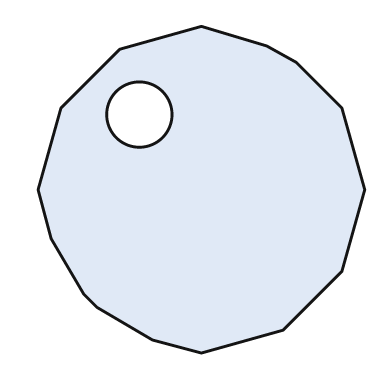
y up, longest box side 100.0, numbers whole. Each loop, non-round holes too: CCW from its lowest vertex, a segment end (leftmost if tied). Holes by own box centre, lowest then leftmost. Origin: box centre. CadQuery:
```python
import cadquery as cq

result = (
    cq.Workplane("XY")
    .moveTo(0.0, -50.0)
    .lineTo(25.0, -43.0)
    .lineTo(43.0, -25.0)
    .lineTo(50.0, 0.0)
    .lineTo(43.0, 25.0)
    .lineTo(29.0, 39.0)
    .lineTo(20.0, 44.0)
    .lineTo(0.0, 50.0)
    .lineTo(-25.0, 43.0)
    .lineTo(-43.0, 25.0)
    .lineTo(-50.0, 0.0)
    .lineTo(-46.0, -15.0)
    .lineTo(-36.0, -32.0)
    .lineTo(-32.0, -36.0)
    .lineTo(-15.0, -46.0)
    .close()
    .moveTo(-19.0, 23.0)
    .circle(10.0)
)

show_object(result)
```